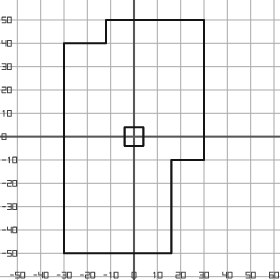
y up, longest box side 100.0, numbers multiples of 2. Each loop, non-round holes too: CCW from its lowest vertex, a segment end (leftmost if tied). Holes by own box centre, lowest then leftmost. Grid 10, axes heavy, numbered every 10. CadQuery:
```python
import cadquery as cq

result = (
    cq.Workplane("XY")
    .moveTo(-30.0, -50.0)
    .lineTo(16.0, -50.0)
    .lineTo(16.0, -10.0)
    .lineTo(30.0, -10.0)
    .lineTo(30.0, 50.0)
    .lineTo(-12.0, 50.0)
    .lineTo(-12.0, 40.0)
    .lineTo(-30.0, 40.0)
    .close()
    .moveTo(-4.0, -4.0)
    .lineTo(4.0, -4.0)
    .lineTo(4.0, 4.0)
    .lineTo(-4.0, 4.0)
    .close()
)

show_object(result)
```